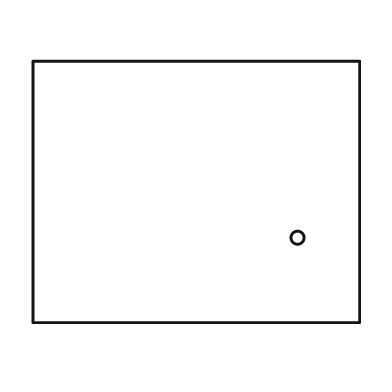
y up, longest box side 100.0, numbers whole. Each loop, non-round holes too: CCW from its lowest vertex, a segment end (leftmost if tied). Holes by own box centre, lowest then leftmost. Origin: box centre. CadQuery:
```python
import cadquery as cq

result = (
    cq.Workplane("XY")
    .moveTo(-50.0, -40.0)
    .lineTo(50.0, -40.0)
    .lineTo(50.0, 40.0)
    .lineTo(-50.0, 40.0)
    .close()
    .moveTo(31.0, -14.0)
    .circle(2.0)
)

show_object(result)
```